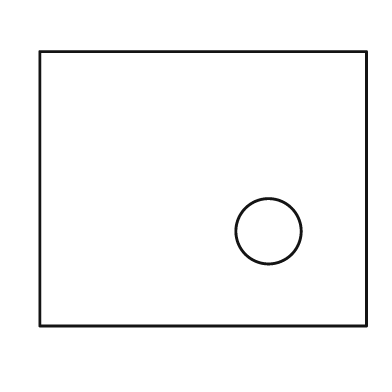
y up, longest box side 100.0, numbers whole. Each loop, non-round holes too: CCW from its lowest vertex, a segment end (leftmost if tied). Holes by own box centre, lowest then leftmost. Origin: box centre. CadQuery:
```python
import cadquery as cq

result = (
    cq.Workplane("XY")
    .moveTo(-50.0, -42.0)
    .lineTo(50.0, -42.0)
    .lineTo(50.0, 42.0)
    .lineTo(-50.0, 42.0)
    .close()
    .moveTo(20.0, -13.0)
    .circle(10.0)
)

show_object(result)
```